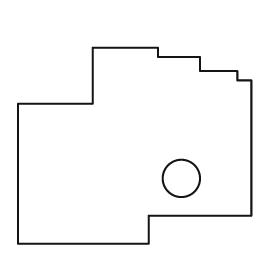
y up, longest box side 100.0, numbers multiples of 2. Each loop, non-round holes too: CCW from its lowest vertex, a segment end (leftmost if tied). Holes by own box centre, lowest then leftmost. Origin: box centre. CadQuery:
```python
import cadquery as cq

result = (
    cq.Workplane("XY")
    .moveTo(-50.0, -42.0)
    .lineTo(6.0, -42.0)
    .lineTo(6.0, -30.0)
    .lineTo(50.0, -30.0)
    .lineTo(50.0, 28.0)
    .lineTo(44.0, 28.0)
    .lineTo(44.0, 32.0)
    .lineTo(28.0, 32.0)
    .lineTo(28.0, 38.0)
    .lineTo(10.0, 38.0)
    .lineTo(10.0, 42.0)
    .lineTo(-18.0, 42.0)
    .lineTo(-18.0, 18.0)
    .lineTo(-50.0, 18.0)
    .close()
    .moveTo(20.0, -14.0)
    .circle(8.0)
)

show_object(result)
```